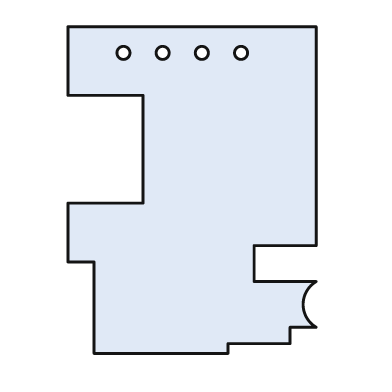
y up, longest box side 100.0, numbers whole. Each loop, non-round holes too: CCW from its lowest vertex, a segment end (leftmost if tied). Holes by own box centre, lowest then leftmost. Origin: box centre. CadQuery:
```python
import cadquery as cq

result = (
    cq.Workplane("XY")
    .moveTo(-30.0, -50.0)
    .lineTo(11.0, -50.0)
    .lineTo(11.0, -47.0)
    .lineTo(30.0, -47.0)
    .lineTo(30.0, -42.0)
    .lineTo(38.0, -42.0)
    .threePointArc((34.0, -35.0), (38.0, -28.0))
    .lineTo(19.0, -28.0)
    .lineTo(19.0, -17.0)
    .lineTo(38.0, -17.0)
    .lineTo(38.0, 50.0)
    .lineTo(-38.0, 50.0)
    .lineTo(-38.0, 29.0)
    .lineTo(-15.0, 29.0)
    .lineTo(-15.0, -4.0)
    .lineTo(-38.0, -4.0)
    .lineTo(-38.0, -22.0)
    .lineTo(-30.0, -22.0)
    .close()
    .moveTo(-21.0, 42.0)
    .circle(2.0)
    .moveTo(-9.0, 42.0)
    .circle(2.0)
    .moveTo(3.0, 42.0)
    .circle(2.0)
    .moveTo(15.0, 42.0)
    .circle(2.0)
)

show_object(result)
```